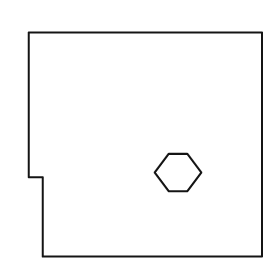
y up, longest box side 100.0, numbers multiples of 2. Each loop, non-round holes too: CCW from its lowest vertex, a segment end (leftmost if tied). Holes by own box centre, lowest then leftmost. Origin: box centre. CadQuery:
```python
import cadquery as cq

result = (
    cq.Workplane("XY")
    .moveTo(-44.0, -48.0)
    .lineTo(50.0, -48.0)
    .lineTo(50.0, 48.0)
    .lineTo(-50.0, 48.0)
    .lineTo(-50.0, -14.0)
    .lineTo(-44.0, -14.0)
    .close()
    .moveTo(10.0, -20.0)
    .lineTo(18.0, -20.0)
    .lineTo(24.0, -12.0)
    .lineTo(18.0, -4.0)
    .lineTo(10.0, -4.0)
    .lineTo(4.0, -12.0)
    .close()
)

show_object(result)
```